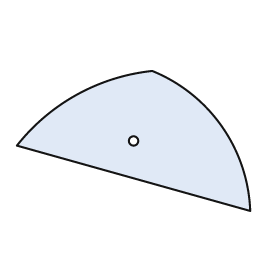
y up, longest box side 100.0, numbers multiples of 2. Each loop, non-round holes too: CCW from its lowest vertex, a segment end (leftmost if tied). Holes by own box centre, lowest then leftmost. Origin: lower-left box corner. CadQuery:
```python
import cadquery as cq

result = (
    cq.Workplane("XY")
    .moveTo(100.0, 0.0)
    .threePointArc((88.0, 36.0), (58.0, 60.0))
    .threePointArc((26.0, 50.0), (0.0, 28.0))
    .close()
    .moveTo(50.0, 30.0)
    .circle(2.0)
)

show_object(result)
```